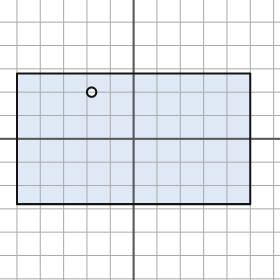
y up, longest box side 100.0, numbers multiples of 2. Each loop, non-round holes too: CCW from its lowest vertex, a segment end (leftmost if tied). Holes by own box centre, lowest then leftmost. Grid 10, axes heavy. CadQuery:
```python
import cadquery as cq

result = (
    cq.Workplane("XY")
    .moveTo(-50.0, -28.0)
    .lineTo(50.0, -28.0)
    .lineTo(50.0, 28.0)
    .lineTo(-50.0, 28.0)
    .close()
    .moveTo(-18.0, 20.0)
    .circle(2.0)
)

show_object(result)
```